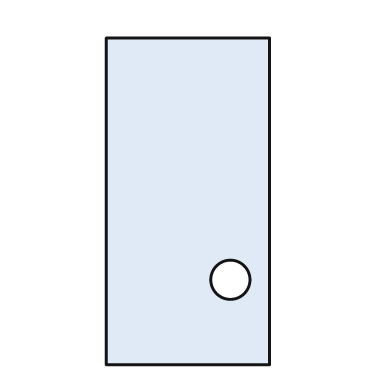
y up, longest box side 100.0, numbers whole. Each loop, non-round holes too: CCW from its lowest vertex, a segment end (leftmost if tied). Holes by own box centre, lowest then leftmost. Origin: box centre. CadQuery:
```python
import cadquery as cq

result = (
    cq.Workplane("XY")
    .moveTo(-25.0, -50.0)
    .lineTo(25.0, -50.0)
    .lineTo(25.0, 50.0)
    .lineTo(-25.0, 50.0)
    .close()
    .moveTo(13.0, -24.0)
    .circle(6.0)
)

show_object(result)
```